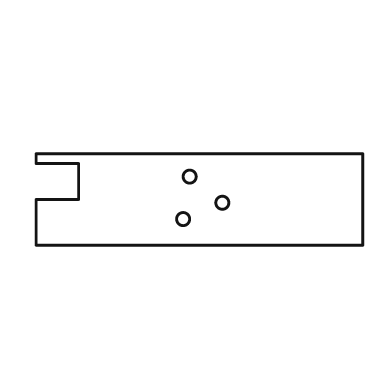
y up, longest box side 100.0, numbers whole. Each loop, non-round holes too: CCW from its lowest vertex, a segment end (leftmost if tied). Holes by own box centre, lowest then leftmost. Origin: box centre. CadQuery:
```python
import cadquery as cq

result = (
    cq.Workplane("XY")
    .moveTo(-50.0, -14.0)
    .lineTo(50.0, -14.0)
    .lineTo(50.0, 14.0)
    .lineTo(-50.0, 14.0)
    .lineTo(-50.0, 11.0)
    .lineTo(-37.0, 11.0)
    .lineTo(-37.0, 0.0)
    .lineTo(-50.0, 0.0)
    .close()
    .moveTo(-5.0, -6.0)
    .circle(2.0)
    .moveTo(7.0, -1.0)
    .circle(2.0)
    .moveTo(-3.0, 7.0)
    .circle(2.0)
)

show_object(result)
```